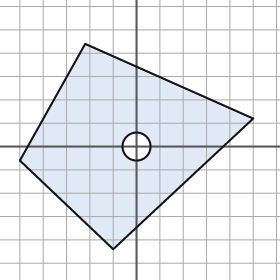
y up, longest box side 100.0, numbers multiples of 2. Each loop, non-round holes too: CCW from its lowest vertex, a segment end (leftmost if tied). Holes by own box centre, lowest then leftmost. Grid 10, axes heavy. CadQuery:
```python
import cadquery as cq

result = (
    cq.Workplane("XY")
    .moveTo(-10.0, -44.0)
    .lineTo(50.0, 12.0)
    .lineTo(-22.0, 44.0)
    .lineTo(-50.0, -6.0)
    .close()
    .moveTo(0.0, 0.0)
    .circle(6.0)
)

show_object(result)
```